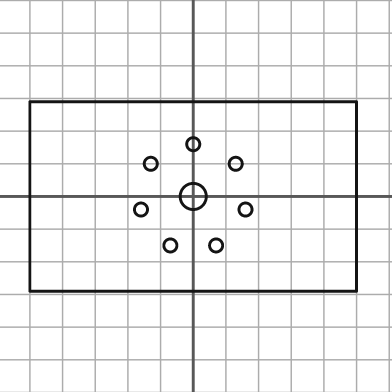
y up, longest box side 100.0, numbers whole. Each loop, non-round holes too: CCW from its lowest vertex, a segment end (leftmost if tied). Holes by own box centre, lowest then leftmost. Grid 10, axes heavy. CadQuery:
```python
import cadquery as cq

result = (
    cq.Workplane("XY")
    .moveTo(-50.0, -29.0)
    .lineTo(50.0, -29.0)
    .lineTo(50.0, 29.0)
    .lineTo(-50.0, 29.0)
    .close()
    .moveTo(-7.0, -15.0)
    .circle(2.0)
    .moveTo(7.0, -15.0)
    .circle(2.0)
    .moveTo(-16.0, -4.0)
    .circle(2.0)
    .moveTo(16.0, -4.0)
    .circle(2.0)
    .moveTo(0.0, 0.0)
    .circle(4.0)
    .moveTo(-13.0, 10.0)
    .circle(2.0)
    .moveTo(13.0, 10.0)
    .circle(2.0)
    .moveTo(0.0, 16.0)
    .circle(2.0)
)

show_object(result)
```